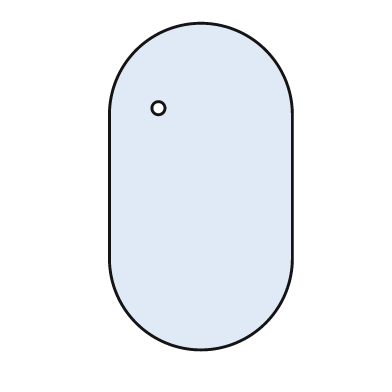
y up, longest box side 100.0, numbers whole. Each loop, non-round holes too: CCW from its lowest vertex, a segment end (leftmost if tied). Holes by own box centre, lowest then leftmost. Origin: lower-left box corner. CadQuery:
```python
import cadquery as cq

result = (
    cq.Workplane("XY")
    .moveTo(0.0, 28.0)
    .threePointArc((28.0, 0.0), (56.0, 28.0))
    .lineTo(56.0, 72.0)
    .threePointArc((28.0, 100.0), (0.0, 72.0))
    .close()
    .moveTo(15.0, 74.0)
    .circle(2.0)
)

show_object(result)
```